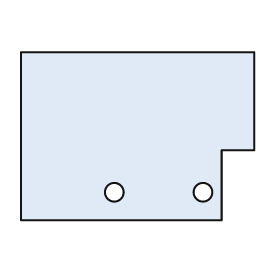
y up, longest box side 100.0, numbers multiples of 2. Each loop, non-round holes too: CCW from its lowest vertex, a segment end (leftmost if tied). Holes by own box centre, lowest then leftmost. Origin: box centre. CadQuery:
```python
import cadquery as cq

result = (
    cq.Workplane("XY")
    .moveTo(-50.0, -36.0)
    .lineTo(36.0, -36.0)
    .lineTo(36.0, -6.0)
    .lineTo(50.0, -6.0)
    .lineTo(50.0, 36.0)
    .lineTo(-50.0, 36.0)
    .close()
    .moveTo(-10.0, -24.0)
    .circle(4.0)
    .moveTo(28.0, -24.0)
    .circle(4.0)
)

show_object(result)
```